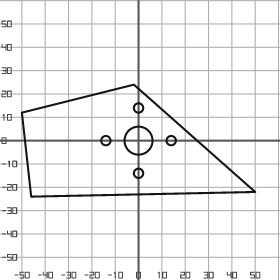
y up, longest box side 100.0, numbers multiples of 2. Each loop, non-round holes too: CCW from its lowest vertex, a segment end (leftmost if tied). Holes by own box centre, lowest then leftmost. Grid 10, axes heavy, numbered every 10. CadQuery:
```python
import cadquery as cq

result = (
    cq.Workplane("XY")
    .moveTo(-46.0, -24.0)
    .lineTo(50.0, -22.0)
    .lineTo(-2.0, 24.0)
    .lineTo(-50.0, 12.0)
    .close()
    .moveTo(0.0, -14.0)
    .circle(2.0)
    .moveTo(-14.0, 0.0)
    .circle(2.0)
    .moveTo(0.0, 0.0)
    .circle(6.0)
    .moveTo(14.0, 0.0)
    .circle(2.0)
    .moveTo(0.0, 14.0)
    .circle(2.0)
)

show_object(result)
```